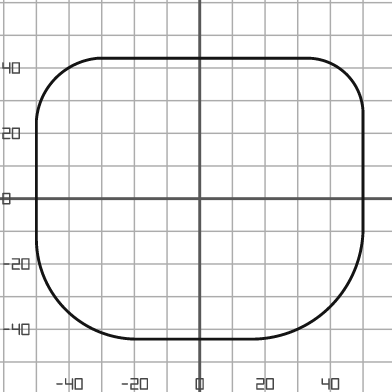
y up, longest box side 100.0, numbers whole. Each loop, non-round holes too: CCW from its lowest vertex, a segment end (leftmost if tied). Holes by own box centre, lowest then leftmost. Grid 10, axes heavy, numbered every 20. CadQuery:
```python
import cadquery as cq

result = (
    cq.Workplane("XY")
    .moveTo(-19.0, -43.0)
    .lineTo(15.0, -43.0)
    .threePointArc((40.0, -33.0), (50.0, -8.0))
    .lineTo(50.0, 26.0)
    .threePointArc((45.0, 38.0), (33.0, 43.0))
    .lineTo(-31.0, 43.0)
    .threePointArc((-44.0, 37.0), (-50.0, 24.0))
    .lineTo(-50.0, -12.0)
    .threePointArc((-41.0, -34.0), (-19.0, -43.0))
    .close()
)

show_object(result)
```